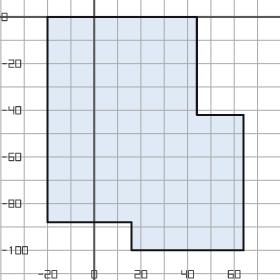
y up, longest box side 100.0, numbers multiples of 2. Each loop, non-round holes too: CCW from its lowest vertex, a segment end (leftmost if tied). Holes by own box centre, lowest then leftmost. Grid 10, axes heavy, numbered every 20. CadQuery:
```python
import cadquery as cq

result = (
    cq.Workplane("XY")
    .moveTo(16.0, -100.0)
    .lineTo(64.0, -100.0)
    .lineTo(64.0, -42.0)
    .lineTo(44.0, -42.0)
    .lineTo(44.0, 0.0)
    .lineTo(-20.0, 0.0)
    .lineTo(-20.0, -88.0)
    .lineTo(16.0, -88.0)
    .close()
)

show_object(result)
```